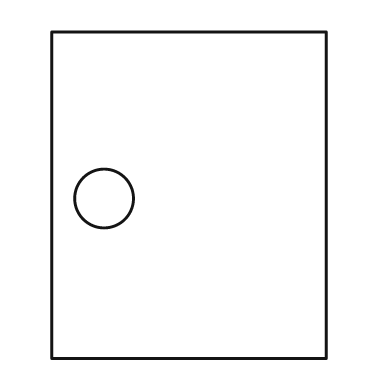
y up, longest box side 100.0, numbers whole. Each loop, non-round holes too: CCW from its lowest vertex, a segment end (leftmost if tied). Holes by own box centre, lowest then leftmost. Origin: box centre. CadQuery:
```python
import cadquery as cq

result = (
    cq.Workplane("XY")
    .moveTo(-42.0, -50.0)
    .lineTo(42.0, -50.0)
    .lineTo(42.0, 50.0)
    .lineTo(-42.0, 50.0)
    .close()
    .moveTo(-26.0, -1.0)
    .circle(9.0)
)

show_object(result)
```